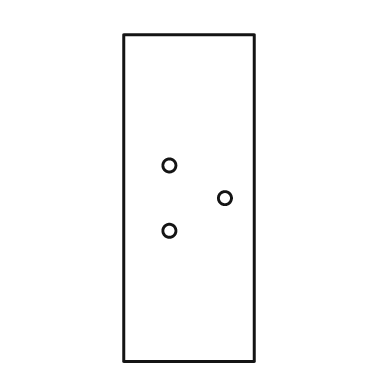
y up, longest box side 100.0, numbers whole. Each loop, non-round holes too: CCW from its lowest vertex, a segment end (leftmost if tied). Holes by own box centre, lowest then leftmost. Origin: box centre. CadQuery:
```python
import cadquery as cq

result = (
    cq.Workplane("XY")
    .moveTo(-20.0, -50.0)
    .lineTo(20.0, -50.0)
    .lineTo(20.0, 50.0)
    .lineTo(-20.0, 50.0)
    .close()
    .moveTo(-6.0, -10.0)
    .circle(2.0)
    .moveTo(11.0, 0.0)
    .circle(2.0)
    .moveTo(-6.0, 10.0)
    .circle(2.0)
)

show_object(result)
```